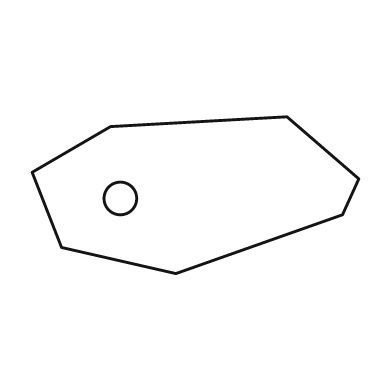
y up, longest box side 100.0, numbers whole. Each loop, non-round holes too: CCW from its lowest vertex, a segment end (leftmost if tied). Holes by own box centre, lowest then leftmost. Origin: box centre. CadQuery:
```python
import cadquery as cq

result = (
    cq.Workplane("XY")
    .moveTo(-6.0, -24.0)
    .lineTo(45.0, -6.0)
    .lineTo(50.0, 5.0)
    .lineTo(28.0, 24.0)
    .lineTo(-26.0, 21.0)
    .lineTo(-50.0, 7.0)
    .lineTo(-41.0, -16.0)
    .close()
    .moveTo(-23.0, -1.0)
    .circle(5.0)
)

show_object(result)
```